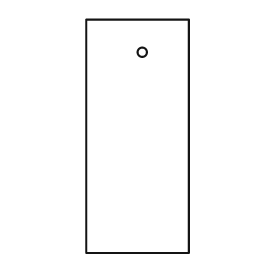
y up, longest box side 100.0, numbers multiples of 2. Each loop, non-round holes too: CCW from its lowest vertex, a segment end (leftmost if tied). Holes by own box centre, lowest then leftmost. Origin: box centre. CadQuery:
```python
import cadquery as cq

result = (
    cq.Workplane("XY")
    .moveTo(-22.0, -50.0)
    .lineTo(22.0, -50.0)
    .lineTo(22.0, 50.0)
    .lineTo(-22.0, 50.0)
    .close()
    .moveTo(2.0, 36.0)
    .circle(2.0)
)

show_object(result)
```